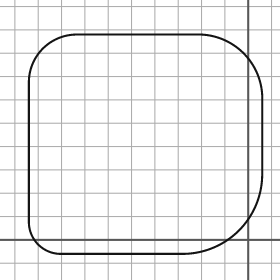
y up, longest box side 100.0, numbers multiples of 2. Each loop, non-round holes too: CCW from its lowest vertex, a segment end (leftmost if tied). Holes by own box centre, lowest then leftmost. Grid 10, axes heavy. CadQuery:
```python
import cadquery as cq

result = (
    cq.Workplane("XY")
    .moveTo(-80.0, -6.0)
    .lineTo(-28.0, -6.0)
    .threePointArc((-4.0, 4.0), (6.0, 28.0))
    .lineTo(6.0, 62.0)
    .threePointArc((-2.0, 80.0), (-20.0, 88.0))
    .lineTo(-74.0, 88.0)
    .threePointArc((-88.0, 82.0), (-94.0, 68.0))
    .lineTo(-94.0, 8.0)
    .threePointArc((-90.0, -2.0), (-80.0, -6.0))
    .close()
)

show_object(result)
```